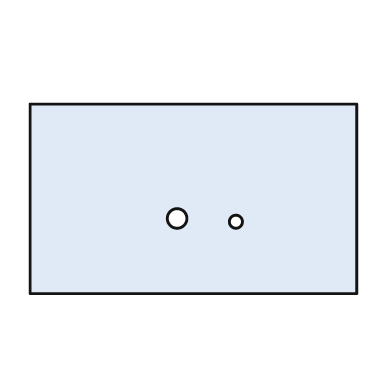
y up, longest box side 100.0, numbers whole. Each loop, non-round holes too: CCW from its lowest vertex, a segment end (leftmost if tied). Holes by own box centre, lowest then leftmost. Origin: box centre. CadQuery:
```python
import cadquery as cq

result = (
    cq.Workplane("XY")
    .moveTo(-50.0, -29.0)
    .lineTo(50.0, -29.0)
    .lineTo(50.0, 29.0)
    .lineTo(-50.0, 29.0)
    .close()
    .moveTo(13.0, -7.0)
    .circle(2.0)
    .moveTo(-5.0, -6.0)
    .circle(3.0)
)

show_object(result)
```